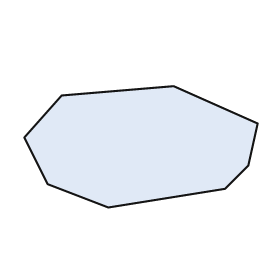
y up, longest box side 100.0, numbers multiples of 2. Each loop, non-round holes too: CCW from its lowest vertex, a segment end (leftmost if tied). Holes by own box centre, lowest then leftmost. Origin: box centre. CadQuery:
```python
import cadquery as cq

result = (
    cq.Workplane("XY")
    .moveTo(-14.0, -26.0)
    .lineTo(36.0, -18.0)
    .lineTo(46.0, -8.0)
    .lineTo(50.0, 10.0)
    .lineTo(14.0, 26.0)
    .lineTo(-34.0, 22.0)
    .lineTo(-50.0, 4.0)
    .lineTo(-40.0, -16.0)
    .close()
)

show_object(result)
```